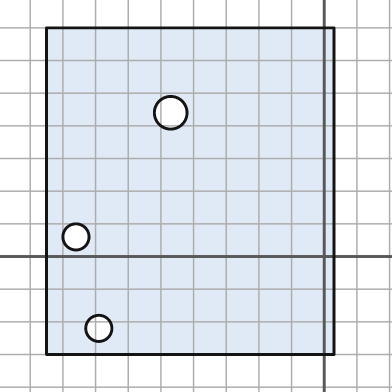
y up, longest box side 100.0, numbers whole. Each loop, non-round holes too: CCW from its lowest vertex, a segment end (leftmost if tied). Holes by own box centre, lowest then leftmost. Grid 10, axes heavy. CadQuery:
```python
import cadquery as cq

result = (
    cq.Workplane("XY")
    .moveTo(-85.0, -30.0)
    .lineTo(3.0, -30.0)
    .lineTo(3.0, 70.0)
    .lineTo(-85.0, 70.0)
    .close()
    .moveTo(-69.0, -22.0)
    .circle(4.0)
    .moveTo(-76.0, 6.0)
    .circle(4.0)
    .moveTo(-47.0, 44.0)
    .circle(5.0)
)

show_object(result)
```